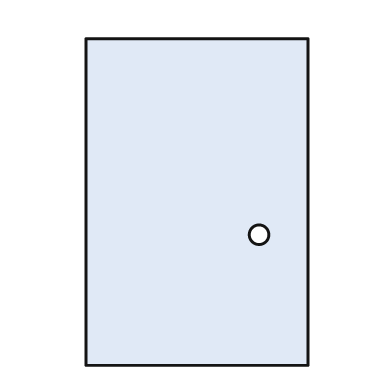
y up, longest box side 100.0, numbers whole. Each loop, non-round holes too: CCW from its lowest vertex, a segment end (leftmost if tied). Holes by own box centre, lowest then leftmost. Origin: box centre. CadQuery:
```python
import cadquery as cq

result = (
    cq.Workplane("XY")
    .moveTo(-34.0, -50.0)
    .lineTo(34.0, -50.0)
    .lineTo(34.0, 50.0)
    .lineTo(-34.0, 50.0)
    .close()
    .moveTo(19.0, -10.0)
    .circle(3.0)
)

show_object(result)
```